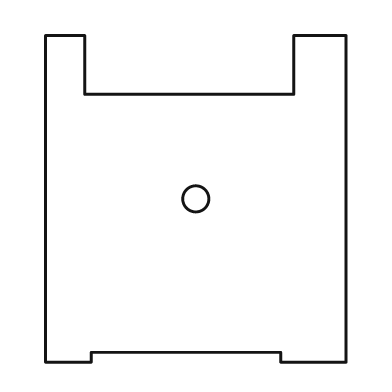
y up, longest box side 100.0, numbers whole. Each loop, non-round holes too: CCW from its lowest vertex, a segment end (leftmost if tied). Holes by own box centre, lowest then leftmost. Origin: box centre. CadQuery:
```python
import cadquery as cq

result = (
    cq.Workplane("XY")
    .moveTo(-46.0, -50.0)
    .lineTo(-32.0, -50.0)
    .lineTo(-32.0, -47.0)
    .lineTo(26.0, -47.0)
    .lineTo(26.0, -50.0)
    .lineTo(46.0, -50.0)
    .lineTo(46.0, 50.0)
    .lineTo(30.0, 50.0)
    .lineTo(30.0, 32.0)
    .lineTo(-34.0, 32.0)
    .lineTo(-34.0, 50.0)
    .lineTo(-46.0, 50.0)
    .close()
    .moveTo(0.0, 0.0)
    .circle(4.0)
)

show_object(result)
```